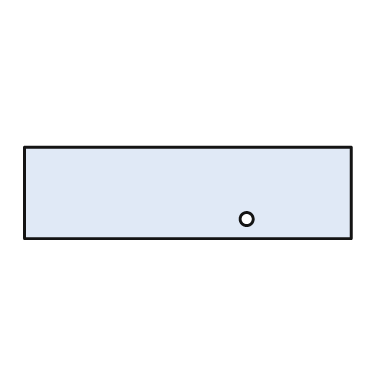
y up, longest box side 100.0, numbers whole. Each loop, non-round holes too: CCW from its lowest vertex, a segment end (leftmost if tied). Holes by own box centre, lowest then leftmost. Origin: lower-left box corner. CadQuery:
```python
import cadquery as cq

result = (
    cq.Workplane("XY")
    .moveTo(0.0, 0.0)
    .lineTo(100.0, 0.0)
    .lineTo(100.0, 28.0)
    .lineTo(0.0, 28.0)
    .close()
    .moveTo(68.0, 6.0)
    .circle(2.0)
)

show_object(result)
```